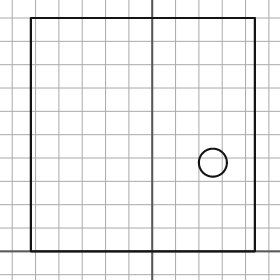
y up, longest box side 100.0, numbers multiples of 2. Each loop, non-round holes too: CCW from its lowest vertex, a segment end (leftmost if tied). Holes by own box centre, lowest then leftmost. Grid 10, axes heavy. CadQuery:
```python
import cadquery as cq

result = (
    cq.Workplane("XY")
    .moveTo(-52.0, 0.0)
    .lineTo(44.0, 0.0)
    .lineTo(44.0, 100.0)
    .lineTo(-52.0, 100.0)
    .close()
    .moveTo(26.0, 38.0)
    .circle(6.0)
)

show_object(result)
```